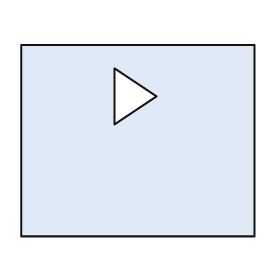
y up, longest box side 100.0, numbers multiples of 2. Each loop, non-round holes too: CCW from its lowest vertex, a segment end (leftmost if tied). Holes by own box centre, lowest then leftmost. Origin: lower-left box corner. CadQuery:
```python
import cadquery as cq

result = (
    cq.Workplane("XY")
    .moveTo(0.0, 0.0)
    .lineTo(100.0, 0.0)
    .lineTo(100.0, 82.0)
    .lineTo(0.0, 82.0)
    .close()
    .moveTo(40.0, 48.0)
    .lineTo(58.0, 60.0)
    .lineTo(40.0, 72.0)
    .close()
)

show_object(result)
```